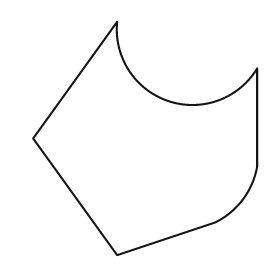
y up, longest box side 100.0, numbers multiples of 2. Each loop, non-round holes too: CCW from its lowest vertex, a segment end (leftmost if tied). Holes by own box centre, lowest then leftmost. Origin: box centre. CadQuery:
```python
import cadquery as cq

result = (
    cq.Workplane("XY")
    .moveTo(-12.0, -50.0)
    .lineTo(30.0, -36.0)
    .threePointArc((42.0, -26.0), (48.0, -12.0))
    .lineTo(48.0, 30.0)
    .threePointArc((10.0, 16.0), (-12.0, 50.0))
    .lineTo(-48.0, 0.0)
    .close()
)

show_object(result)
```